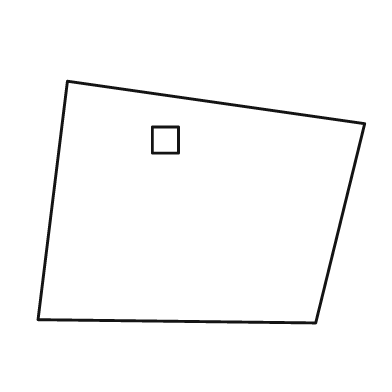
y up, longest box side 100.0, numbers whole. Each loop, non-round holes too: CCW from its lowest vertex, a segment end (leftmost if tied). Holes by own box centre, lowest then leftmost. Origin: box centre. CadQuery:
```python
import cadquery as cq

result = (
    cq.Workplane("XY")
    .moveTo(35.0, -37.0)
    .lineTo(50.0, 24.0)
    .lineTo(-41.0, 37.0)
    .lineTo(-50.0, -36.0)
    .close()
    .moveTo(-15.0, 15.0)
    .lineTo(-7.0, 15.0)
    .lineTo(-7.0, 23.0)
    .lineTo(-15.0, 23.0)
    .close()
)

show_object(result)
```